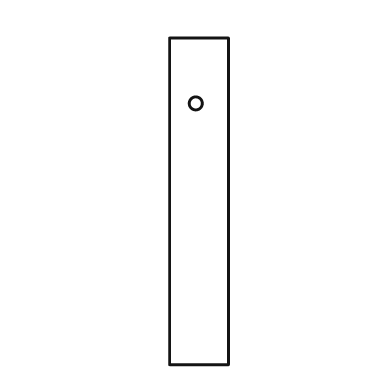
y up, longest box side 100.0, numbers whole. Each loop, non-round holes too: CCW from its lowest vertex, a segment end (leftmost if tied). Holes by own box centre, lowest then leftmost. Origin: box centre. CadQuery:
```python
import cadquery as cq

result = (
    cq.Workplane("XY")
    .moveTo(-9.0, -50.0)
    .lineTo(9.0, -50.0)
    .lineTo(9.0, 50.0)
    .lineTo(-9.0, 50.0)
    .close()
    .moveTo(-1.0, 30.0)
    .circle(2.0)
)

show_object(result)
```